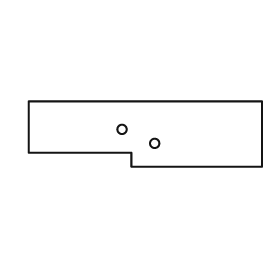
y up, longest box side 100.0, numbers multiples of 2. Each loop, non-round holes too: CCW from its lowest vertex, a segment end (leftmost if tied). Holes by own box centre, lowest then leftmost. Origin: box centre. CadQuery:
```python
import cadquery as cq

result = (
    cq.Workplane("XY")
    .moveTo(-6.0, -14.0)
    .lineTo(50.0, -14.0)
    .lineTo(50.0, 14.0)
    .lineTo(-50.0, 14.0)
    .lineTo(-50.0, -8.0)
    .lineTo(-6.0, -8.0)
    .close()
    .moveTo(4.0, -4.0)
    .circle(2.0)
    .moveTo(-10.0, 2.0)
    .circle(2.0)
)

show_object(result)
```